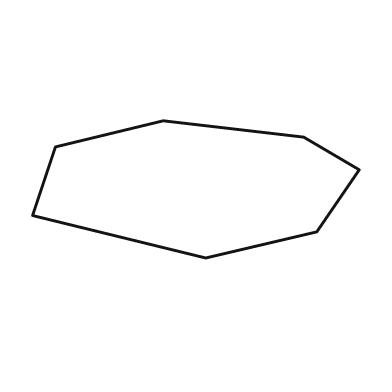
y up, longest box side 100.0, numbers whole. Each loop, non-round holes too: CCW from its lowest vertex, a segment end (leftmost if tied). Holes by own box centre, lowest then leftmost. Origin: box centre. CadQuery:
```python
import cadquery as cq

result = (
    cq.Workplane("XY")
    .moveTo(3.0, -21.0)
    .lineTo(37.0, -13.0)
    .lineTo(50.0, 6.0)
    .lineTo(33.0, 16.0)
    .lineTo(-10.0, 21.0)
    .lineTo(-43.0, 13.0)
    .lineTo(-50.0, -8.0)
    .close()
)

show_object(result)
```